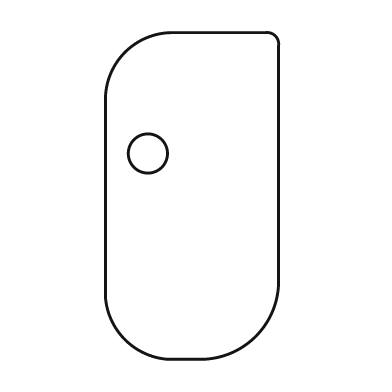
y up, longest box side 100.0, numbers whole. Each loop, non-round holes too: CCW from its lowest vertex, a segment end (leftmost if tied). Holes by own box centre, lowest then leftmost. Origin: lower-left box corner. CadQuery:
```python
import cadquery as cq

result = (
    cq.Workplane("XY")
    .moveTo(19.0, 0.0)
    .lineTo(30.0, 0.0)
    .threePointArc((46.0, 7.0), (53.0, 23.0))
    .lineTo(53.0, 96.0)
    .threePointArc((52.0, 99.0), (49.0, 100.0))
    .lineTo(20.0, 100.0)
    .threePointArc((6.0, 94.0), (0.0, 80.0))
    .lineTo(0.0, 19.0)
    .threePointArc((6.0, 6.0), (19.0, 0.0))
    .close()
    .moveTo(13.0, 63.0)
    .circle(6.0)
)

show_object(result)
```